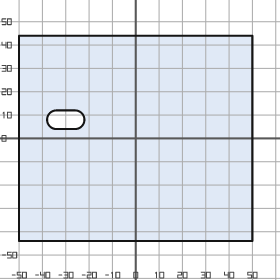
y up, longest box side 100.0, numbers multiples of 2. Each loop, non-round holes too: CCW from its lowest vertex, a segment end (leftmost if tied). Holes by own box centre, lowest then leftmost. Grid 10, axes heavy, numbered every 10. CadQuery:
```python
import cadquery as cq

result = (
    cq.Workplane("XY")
    .moveTo(-50.0, -44.0)
    .lineTo(50.0, -44.0)
    .lineTo(50.0, 44.0)
    .lineTo(-50.0, 44.0)
    .close()
    .moveTo(-34.0, 4.0)
    .lineTo(-26.0, 4.0)
    .threePointArc((-22.0, 8.0), (-26.0, 12.0))
    .lineTo(-34.0, 12.0)
    .threePointArc((-38.0, 8.0), (-34.0, 4.0))
    .close()
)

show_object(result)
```